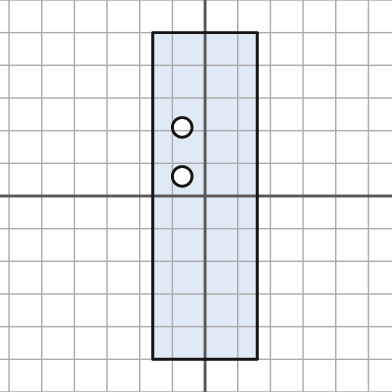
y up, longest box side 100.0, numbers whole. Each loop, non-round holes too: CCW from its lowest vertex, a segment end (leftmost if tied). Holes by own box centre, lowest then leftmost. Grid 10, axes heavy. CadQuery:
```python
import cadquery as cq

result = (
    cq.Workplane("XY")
    .moveTo(-16.0, -50.0)
    .lineTo(16.0, -50.0)
    .lineTo(16.0, 50.0)
    .lineTo(-16.0, 50.0)
    .close()
    .moveTo(-7.0, 6.0)
    .circle(3.0)
    .moveTo(-7.0, 21.0)
    .circle(3.0)
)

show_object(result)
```